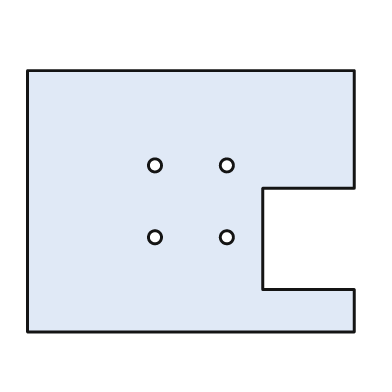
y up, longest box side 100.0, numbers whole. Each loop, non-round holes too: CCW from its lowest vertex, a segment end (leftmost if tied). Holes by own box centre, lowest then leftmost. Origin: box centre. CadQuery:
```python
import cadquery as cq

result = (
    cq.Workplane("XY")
    .moveTo(-50.0, -40.0)
    .lineTo(50.0, -40.0)
    .lineTo(50.0, -27.0)
    .lineTo(22.0, -27.0)
    .lineTo(22.0, 4.0)
    .lineTo(50.0, 4.0)
    .lineTo(50.0, 40.0)
    .lineTo(-50.0, 40.0)
    .close()
    .moveTo(-11.0, -11.0)
    .circle(2.0)
    .moveTo(11.0, -11.0)
    .circle(2.0)
    .moveTo(-11.0, 11.0)
    .circle(2.0)
    .moveTo(11.0, 11.0)
    .circle(2.0)
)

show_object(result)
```